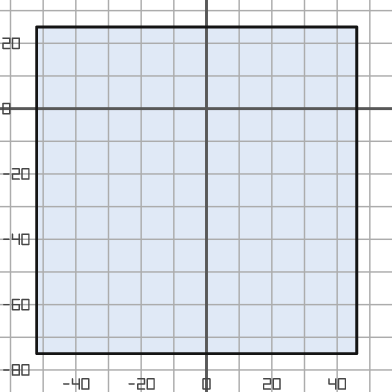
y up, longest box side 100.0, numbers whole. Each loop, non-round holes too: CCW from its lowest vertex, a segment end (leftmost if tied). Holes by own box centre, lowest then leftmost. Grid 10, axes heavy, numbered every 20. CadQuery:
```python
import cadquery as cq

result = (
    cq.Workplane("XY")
    .moveTo(-52.0, -75.0)
    .lineTo(46.0, -75.0)
    .lineTo(46.0, 25.0)
    .lineTo(-52.0, 25.0)
    .close()
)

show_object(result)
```